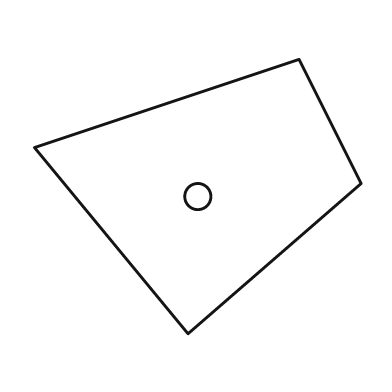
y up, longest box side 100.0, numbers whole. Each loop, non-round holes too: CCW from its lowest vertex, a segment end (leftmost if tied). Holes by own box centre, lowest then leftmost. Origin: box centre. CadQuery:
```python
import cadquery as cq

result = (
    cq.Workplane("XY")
    .moveTo(-3.0, -42.0)
    .lineTo(50.0, 4.0)
    .lineTo(31.0, 42.0)
    .lineTo(-50.0, 15.0)
    .close()
    .moveTo(0.0, 0.0)
    .circle(4.0)
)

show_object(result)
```